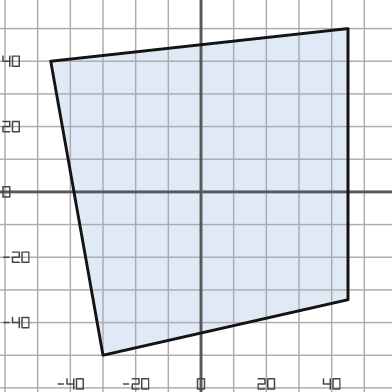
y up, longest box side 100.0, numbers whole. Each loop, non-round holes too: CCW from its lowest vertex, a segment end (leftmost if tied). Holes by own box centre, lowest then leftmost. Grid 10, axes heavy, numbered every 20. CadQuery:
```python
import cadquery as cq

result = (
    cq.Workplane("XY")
    .moveTo(-30.0, -50.0)
    .lineTo(45.0, -33.0)
    .lineTo(45.0, 50.0)
    .lineTo(-46.0, 40.0)
    .close()
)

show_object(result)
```